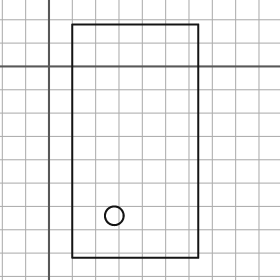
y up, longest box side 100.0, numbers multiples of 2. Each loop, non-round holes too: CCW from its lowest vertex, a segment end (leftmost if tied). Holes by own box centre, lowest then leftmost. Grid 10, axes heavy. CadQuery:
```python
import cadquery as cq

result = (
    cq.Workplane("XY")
    .moveTo(10.0, -82.0)
    .lineTo(64.0, -82.0)
    .lineTo(64.0, 18.0)
    .lineTo(10.0, 18.0)
    .close()
    .moveTo(28.0, -64.0)
    .circle(4.0)
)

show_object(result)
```